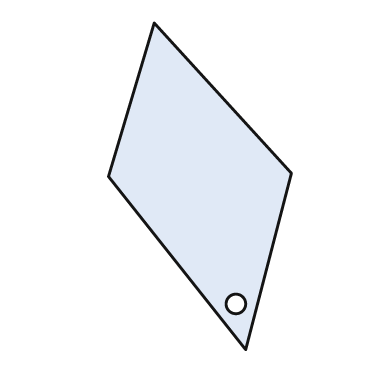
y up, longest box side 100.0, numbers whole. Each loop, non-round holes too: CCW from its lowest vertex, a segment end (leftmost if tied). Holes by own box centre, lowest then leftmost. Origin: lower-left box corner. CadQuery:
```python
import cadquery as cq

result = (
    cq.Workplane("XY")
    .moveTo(42.0, 0.0)
    .lineTo(56.0, 54.0)
    .lineTo(14.0, 100.0)
    .lineTo(0.0, 53.0)
    .close()
    .moveTo(39.0, 14.0)
    .circle(3.0)
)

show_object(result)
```